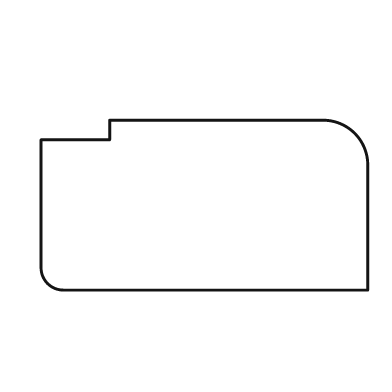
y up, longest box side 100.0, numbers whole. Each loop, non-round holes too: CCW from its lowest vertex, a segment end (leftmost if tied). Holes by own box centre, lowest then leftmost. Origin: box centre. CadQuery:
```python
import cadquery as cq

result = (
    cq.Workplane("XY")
    .moveTo(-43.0, -26.0)
    .lineTo(50.0, -26.0)
    .lineTo(50.0, 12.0)
    .threePointArc((46.0, 22.0), (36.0, 26.0))
    .lineTo(-29.0, 26.0)
    .lineTo(-29.0, 20.0)
    .lineTo(-50.0, 20.0)
    .lineTo(-50.0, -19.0)
    .threePointArc((-48.0, -24.0), (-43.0, -26.0))
    .close()
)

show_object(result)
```